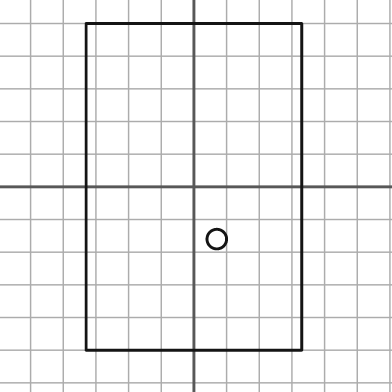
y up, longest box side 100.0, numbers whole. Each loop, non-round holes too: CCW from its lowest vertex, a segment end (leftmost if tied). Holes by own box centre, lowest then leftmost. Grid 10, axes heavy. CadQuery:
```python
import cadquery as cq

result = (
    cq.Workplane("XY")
    .moveTo(-33.0, -50.0)
    .lineTo(33.0, -50.0)
    .lineTo(33.0, 50.0)
    .lineTo(-33.0, 50.0)
    .close()
    .moveTo(7.0, -16.0)
    .circle(3.0)
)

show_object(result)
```